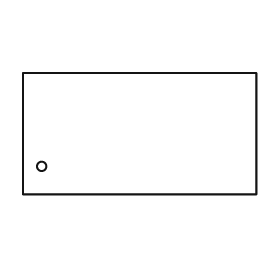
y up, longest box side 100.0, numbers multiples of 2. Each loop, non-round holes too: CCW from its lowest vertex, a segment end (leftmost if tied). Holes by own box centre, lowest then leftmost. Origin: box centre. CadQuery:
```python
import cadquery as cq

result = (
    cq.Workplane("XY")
    .moveTo(-50.0, -26.0)
    .lineTo(50.0, -26.0)
    .lineTo(50.0, 26.0)
    .lineTo(-50.0, 26.0)
    .close()
    .moveTo(-42.0, -14.0)
    .circle(2.0)
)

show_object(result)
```